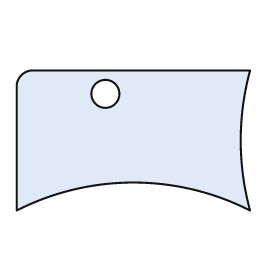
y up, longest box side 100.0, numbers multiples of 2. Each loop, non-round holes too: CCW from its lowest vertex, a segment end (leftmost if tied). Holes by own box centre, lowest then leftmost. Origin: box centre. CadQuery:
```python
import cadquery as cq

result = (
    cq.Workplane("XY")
    .moveTo(-50.0, -30.0)
    .threePointArc((0.0, -18.0), (50.0, -30.0))
    .threePointArc((46.0, 0.0), (50.0, 30.0))
    .lineTo(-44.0, 30.0)
    .threePointArc((-48.0, 28.0), (-50.0, 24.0))
    .close()
    .moveTo(-12.0, 20.0)
    .circle(6.0)
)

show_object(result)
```